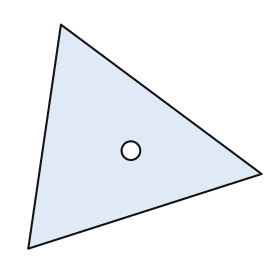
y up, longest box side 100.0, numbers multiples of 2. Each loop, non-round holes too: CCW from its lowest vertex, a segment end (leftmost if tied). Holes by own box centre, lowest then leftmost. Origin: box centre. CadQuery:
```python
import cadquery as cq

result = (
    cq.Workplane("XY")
    .moveTo(-50.0, -48.0)
    .lineTo(50.0, -16.0)
    .lineTo(-36.0, 48.0)
    .close()
    .moveTo(-6.0, -6.0)
    .circle(4.0)
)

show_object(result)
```